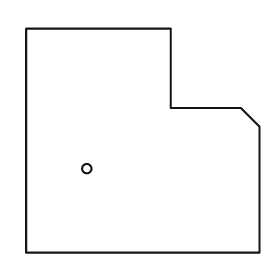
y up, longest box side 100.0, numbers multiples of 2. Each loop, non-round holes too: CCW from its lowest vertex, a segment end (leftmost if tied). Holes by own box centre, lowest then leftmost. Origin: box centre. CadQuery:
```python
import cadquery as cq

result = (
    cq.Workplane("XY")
    .moveTo(-50.0, -48.0)
    .lineTo(50.0, -48.0)
    .lineTo(50.0, 6.0)
    .lineTo(42.0, 14.0)
    .lineTo(12.0, 14.0)
    .lineTo(12.0, 48.0)
    .lineTo(-50.0, 48.0)
    .close()
    .moveTo(-24.0, -12.0)
    .circle(2.0)
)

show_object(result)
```